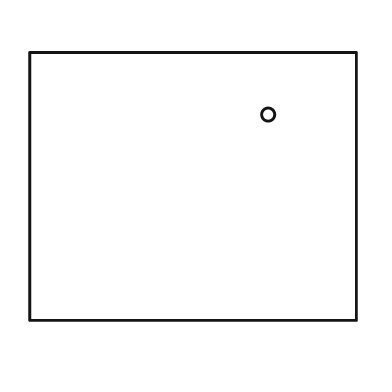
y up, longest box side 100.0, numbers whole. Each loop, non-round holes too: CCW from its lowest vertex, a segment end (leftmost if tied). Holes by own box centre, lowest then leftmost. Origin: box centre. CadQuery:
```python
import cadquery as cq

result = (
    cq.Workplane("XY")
    .moveTo(-50.0, -41.0)
    .lineTo(50.0, -41.0)
    .lineTo(50.0, 41.0)
    .lineTo(-50.0, 41.0)
    .close()
    .moveTo(23.0, 22.0)
    .circle(2.0)
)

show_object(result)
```